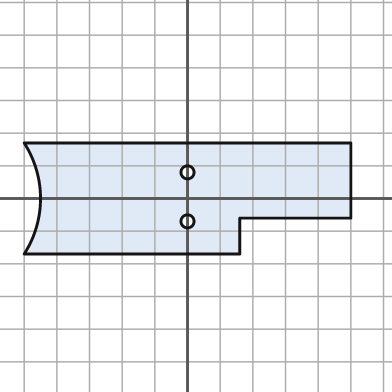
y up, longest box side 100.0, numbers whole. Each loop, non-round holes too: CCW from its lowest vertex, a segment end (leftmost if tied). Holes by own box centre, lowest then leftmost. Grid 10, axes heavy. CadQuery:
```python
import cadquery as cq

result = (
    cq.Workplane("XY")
    .moveTo(-50.0, -17.0)
    .lineTo(16.0, -17.0)
    .lineTo(16.0, -6.0)
    .lineTo(50.0, -6.0)
    .lineTo(50.0, 17.0)
    .lineTo(-50.0, 17.0)
    .threePointArc((-45.0, 0.0), (-50.0, -17.0))
    .close()
    .moveTo(0.0, -7.0)
    .circle(2.0)
    .moveTo(0.0, 8.0)
    .circle(2.0)
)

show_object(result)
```